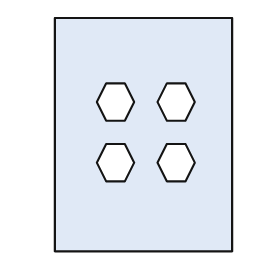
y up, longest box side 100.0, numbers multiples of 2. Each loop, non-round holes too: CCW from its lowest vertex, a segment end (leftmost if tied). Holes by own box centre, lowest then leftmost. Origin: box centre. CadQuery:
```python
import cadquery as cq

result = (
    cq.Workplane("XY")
    .moveTo(-38.0, -50.0)
    .lineTo(38.0, -50.0)
    .lineTo(38.0, 50.0)
    .lineTo(-38.0, 50.0)
    .close()
    .moveTo(-16.0, -20.0)
    .lineTo(-8.0, -20.0)
    .lineTo(-4.0, -12.0)
    .lineTo(-8.0, -4.0)
    .lineTo(-16.0, -4.0)
    .lineTo(-20.0, -12.0)
    .close()
    .moveTo(10.0, -20.0)
    .lineTo(18.0, -20.0)
    .lineTo(22.0, -12.0)
    .lineTo(18.0, -4.0)
    .lineTo(10.0, -4.0)
    .lineTo(6.0, -12.0)
    .close()
    .moveTo(-16.0, 6.0)
    .lineTo(-8.0, 6.0)
    .lineTo(-4.0, 14.0)
    .lineTo(-8.0, 22.0)
    .lineTo(-16.0, 22.0)
    .lineTo(-20.0, 14.0)
    .close()
    .moveTo(10.0, 6.0)
    .lineTo(18.0, 6.0)
    .lineTo(22.0, 14.0)
    .lineTo(18.0, 22.0)
    .lineTo(10.0, 22.0)
    .lineTo(6.0, 14.0)
    .close()
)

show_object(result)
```